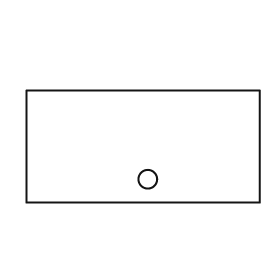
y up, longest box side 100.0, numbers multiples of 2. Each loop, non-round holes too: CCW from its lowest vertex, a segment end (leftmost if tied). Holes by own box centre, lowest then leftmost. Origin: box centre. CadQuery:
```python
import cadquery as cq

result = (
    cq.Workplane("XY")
    .moveTo(-50.0, -24.0)
    .lineTo(50.0, -24.0)
    .lineTo(50.0, 24.0)
    .lineTo(-50.0, 24.0)
    .close()
    .moveTo(2.0, -14.0)
    .circle(4.0)
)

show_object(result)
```